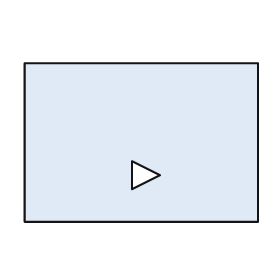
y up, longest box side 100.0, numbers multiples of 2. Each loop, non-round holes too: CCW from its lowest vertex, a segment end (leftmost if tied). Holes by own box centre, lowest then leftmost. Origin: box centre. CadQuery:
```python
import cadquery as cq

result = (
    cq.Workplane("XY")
    .moveTo(-50.0, -34.0)
    .lineTo(50.0, -34.0)
    .lineTo(50.0, 34.0)
    .lineTo(-50.0, 34.0)
    .close()
    .moveTo(-4.0, -20.0)
    .lineTo(8.0, -14.0)
    .lineTo(-4.0, -8.0)
    .close()
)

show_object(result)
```